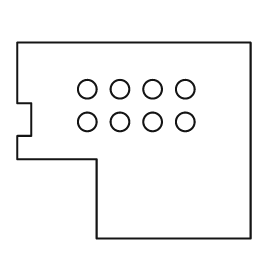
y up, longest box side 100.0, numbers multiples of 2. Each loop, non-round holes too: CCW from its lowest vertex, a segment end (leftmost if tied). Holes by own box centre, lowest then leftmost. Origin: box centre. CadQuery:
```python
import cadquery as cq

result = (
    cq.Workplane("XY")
    .moveTo(-16.0, -42.0)
    .lineTo(50.0, -42.0)
    .lineTo(50.0, 42.0)
    .lineTo(-50.0, 42.0)
    .lineTo(-50.0, 16.0)
    .lineTo(-44.0, 16.0)
    .lineTo(-44.0, 2.0)
    .lineTo(-50.0, 2.0)
    .lineTo(-50.0, -8.0)
    .lineTo(-16.0, -8.0)
    .close()
    .moveTo(-20.0, 8.0)
    .circle(4.0)
    .moveTo(-6.0, 8.0)
    .circle(4.0)
    .moveTo(8.0, 8.0)
    .circle(4.0)
    .moveTo(22.0, 8.0)
    .circle(4.0)
    .moveTo(-20.0, 22.0)
    .circle(4.0)
    .moveTo(-6.0, 22.0)
    .circle(4.0)
    .moveTo(8.0, 22.0)
    .circle(4.0)
    .moveTo(22.0, 22.0)
    .circle(4.0)
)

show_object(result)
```